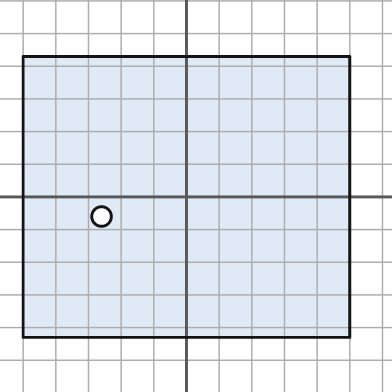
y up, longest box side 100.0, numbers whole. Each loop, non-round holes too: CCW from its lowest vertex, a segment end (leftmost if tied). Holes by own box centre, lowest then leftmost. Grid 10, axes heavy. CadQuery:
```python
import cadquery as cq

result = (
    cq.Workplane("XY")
    .moveTo(-50.0, -43.0)
    .lineTo(50.0, -43.0)
    .lineTo(50.0, 43.0)
    .lineTo(-50.0, 43.0)
    .close()
    .moveTo(-26.0, -6.0)
    .circle(3.0)
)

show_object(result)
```